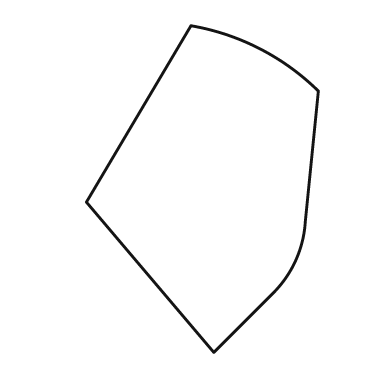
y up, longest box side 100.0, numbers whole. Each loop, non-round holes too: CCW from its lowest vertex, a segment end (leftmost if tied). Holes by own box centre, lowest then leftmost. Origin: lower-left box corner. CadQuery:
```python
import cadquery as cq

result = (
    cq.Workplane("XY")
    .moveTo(39.0, 0.0)
    .lineTo(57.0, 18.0)
    .threePointArc((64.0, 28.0), (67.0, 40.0))
    .lineTo(71.0, 80.0)
    .threePointArc((53.0, 93.0), (32.0, 100.0))
    .lineTo(0.0, 46.0)
    .close()
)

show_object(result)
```